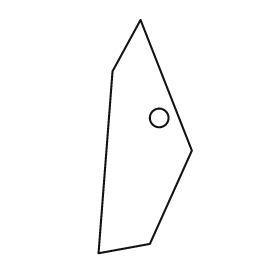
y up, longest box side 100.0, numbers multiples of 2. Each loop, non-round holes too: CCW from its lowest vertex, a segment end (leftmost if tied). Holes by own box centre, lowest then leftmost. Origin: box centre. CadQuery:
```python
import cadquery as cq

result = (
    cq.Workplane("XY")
    .moveTo(-20.0, -50.0)
    .lineTo(2.0, -46.0)
    .lineTo(20.0, -6.0)
    .lineTo(-2.0, 50.0)
    .lineTo(-14.0, 28.0)
    .close()
    .moveTo(6.0, 8.0)
    .circle(4.0)
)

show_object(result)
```